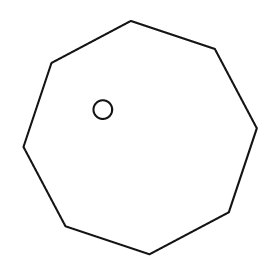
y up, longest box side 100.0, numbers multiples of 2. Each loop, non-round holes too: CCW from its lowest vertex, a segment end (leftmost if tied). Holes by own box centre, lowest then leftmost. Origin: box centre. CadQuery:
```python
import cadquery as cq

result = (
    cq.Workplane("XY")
    .moveTo(4.0, -50.0)
    .lineTo(38.0, -32.0)
    .lineTo(50.0, 4.0)
    .lineTo(32.0, 38.0)
    .lineTo(-4.0, 50.0)
    .lineTo(-38.0, 32.0)
    .lineTo(-50.0, -4.0)
    .lineTo(-32.0, -38.0)
    .close()
    .moveTo(-16.0, 12.0)
    .circle(4.0)
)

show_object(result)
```